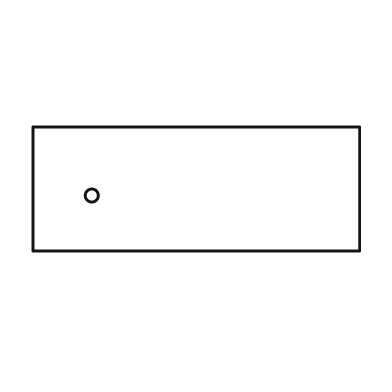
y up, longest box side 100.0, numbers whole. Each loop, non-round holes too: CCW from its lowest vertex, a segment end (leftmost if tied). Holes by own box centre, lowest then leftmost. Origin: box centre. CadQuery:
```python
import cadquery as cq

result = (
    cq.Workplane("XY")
    .moveTo(-50.0, -19.0)
    .lineTo(50.0, -19.0)
    .lineTo(50.0, 19.0)
    .lineTo(-50.0, 19.0)
    .close()
    .moveTo(-32.0, -2.0)
    .circle(2.0)
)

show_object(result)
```